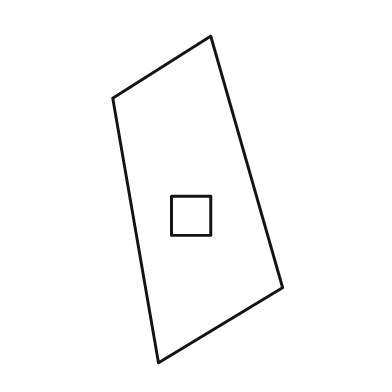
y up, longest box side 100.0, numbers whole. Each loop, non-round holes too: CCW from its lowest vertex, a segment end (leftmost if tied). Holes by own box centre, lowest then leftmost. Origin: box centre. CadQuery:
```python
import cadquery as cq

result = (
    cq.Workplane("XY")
    .moveTo(-12.0, -50.0)
    .lineTo(26.0, -27.0)
    .lineTo(4.0, 50.0)
    .lineTo(-26.0, 31.0)
    .close()
    .moveTo(-8.0, -11.0)
    .lineTo(4.0, -11.0)
    .lineTo(4.0, 1.0)
    .lineTo(-8.0, 1.0)
    .close()
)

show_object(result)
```